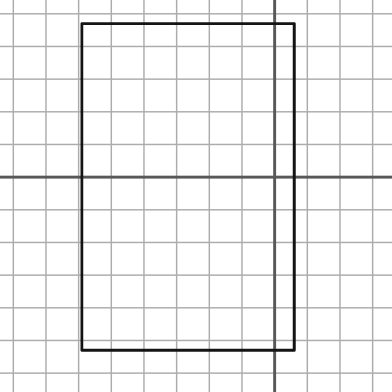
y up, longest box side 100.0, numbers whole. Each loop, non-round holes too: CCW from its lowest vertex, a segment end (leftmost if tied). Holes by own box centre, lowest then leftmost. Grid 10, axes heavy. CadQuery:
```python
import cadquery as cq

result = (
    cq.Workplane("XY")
    .moveTo(-59.0, -53.0)
    .lineTo(6.0, -53.0)
    .lineTo(6.0, 47.0)
    .lineTo(-59.0, 47.0)
    .close()
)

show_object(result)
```